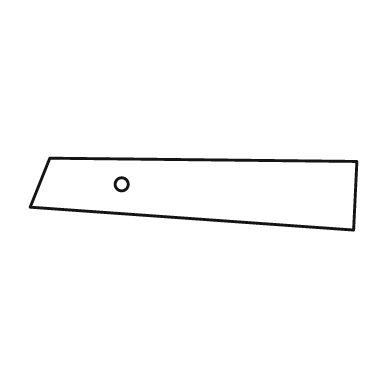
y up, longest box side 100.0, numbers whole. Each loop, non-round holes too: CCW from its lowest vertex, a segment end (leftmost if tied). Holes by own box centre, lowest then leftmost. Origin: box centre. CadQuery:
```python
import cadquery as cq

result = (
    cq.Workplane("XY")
    .moveTo(49.0, -11.0)
    .lineTo(50.0, 10.0)
    .lineTo(-44.0, 11.0)
    .lineTo(-50.0, -4.0)
    .close()
    .moveTo(-22.0, 3.0)
    .circle(2.0)
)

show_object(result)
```